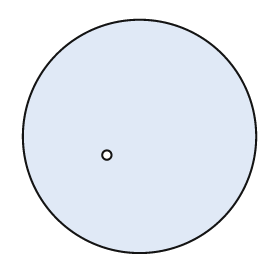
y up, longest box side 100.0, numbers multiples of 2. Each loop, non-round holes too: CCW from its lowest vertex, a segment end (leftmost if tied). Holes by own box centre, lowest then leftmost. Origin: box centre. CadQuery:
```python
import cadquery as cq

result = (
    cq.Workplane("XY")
    .moveTo(0.0, 0.0)
    .circle(50.0)
    .moveTo(-14.0, -8.0)
    .circle(2.0)
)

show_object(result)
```